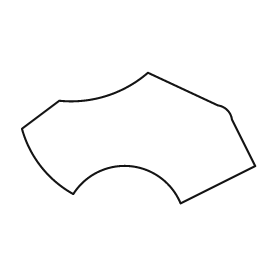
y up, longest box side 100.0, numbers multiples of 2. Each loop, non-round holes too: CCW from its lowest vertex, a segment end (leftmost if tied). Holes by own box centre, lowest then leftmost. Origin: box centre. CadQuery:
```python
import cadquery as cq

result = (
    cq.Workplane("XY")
    .moveTo(18.0, -28.0)
    .lineTo(50.0, -12.0)
    .lineTo(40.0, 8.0)
    .threePointArc((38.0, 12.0), (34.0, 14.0))
    .lineTo(4.0, 28.0)
    .threePointArc((-14.0, 18.0), (-34.0, 16.0))
    .lineTo(-50.0, 4.0)
    .threePointArc((-42.0, -12.0), (-28.0, -24.0))
    .threePointArc((-4.0, -12.0), (18.0, -28.0))
    .close()
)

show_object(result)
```